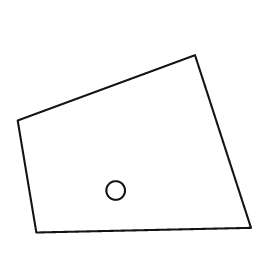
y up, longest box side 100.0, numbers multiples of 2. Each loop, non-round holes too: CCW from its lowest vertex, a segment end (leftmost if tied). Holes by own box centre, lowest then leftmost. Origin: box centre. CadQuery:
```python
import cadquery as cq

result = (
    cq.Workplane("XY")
    .moveTo(-42.0, -38.0)
    .lineTo(50.0, -36.0)
    .lineTo(26.0, 38.0)
    .lineTo(-50.0, 10.0)
    .close()
    .moveTo(-8.0, -20.0)
    .circle(4.0)
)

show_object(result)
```